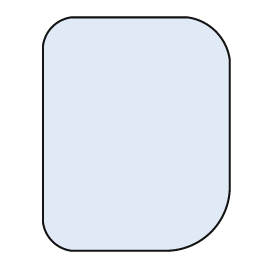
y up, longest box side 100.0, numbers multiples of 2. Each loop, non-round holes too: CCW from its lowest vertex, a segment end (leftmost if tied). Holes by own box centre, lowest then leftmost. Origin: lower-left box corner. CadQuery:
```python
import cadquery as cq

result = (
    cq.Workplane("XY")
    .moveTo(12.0, 0.0)
    .lineTo(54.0, 0.0)
    .threePointArc((72.0, 8.0), (80.0, 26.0))
    .lineTo(80.0, 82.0)
    .threePointArc((74.0, 94.0), (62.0, 100.0))
    .lineTo(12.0, 100.0)
    .threePointArc((4.0, 96.0), (0.0, 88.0))
    .lineTo(0.0, 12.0)
    .threePointArc((4.0, 4.0), (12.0, 0.0))
    .close()
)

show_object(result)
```